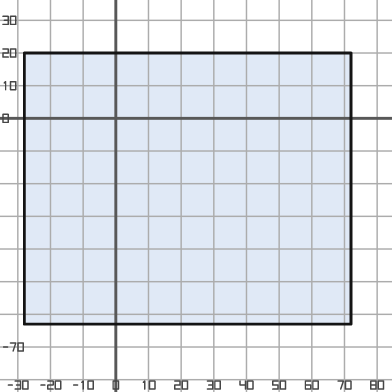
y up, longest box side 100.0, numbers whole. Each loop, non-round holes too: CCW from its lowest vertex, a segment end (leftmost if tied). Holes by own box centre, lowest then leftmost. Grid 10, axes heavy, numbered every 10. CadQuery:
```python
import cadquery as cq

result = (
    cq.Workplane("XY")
    .moveTo(-28.0, -63.0)
    .lineTo(72.0, -63.0)
    .lineTo(72.0, 20.0)
    .lineTo(-28.0, 20.0)
    .close()
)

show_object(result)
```